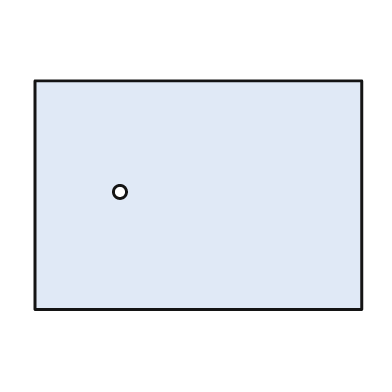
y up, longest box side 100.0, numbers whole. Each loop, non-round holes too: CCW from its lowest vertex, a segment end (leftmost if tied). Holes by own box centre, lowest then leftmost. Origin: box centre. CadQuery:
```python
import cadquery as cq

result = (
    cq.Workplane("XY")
    .moveTo(-50.0, -35.0)
    .lineTo(50.0, -35.0)
    .lineTo(50.0, 35.0)
    .lineTo(-50.0, 35.0)
    .close()
    .moveTo(-24.0, 1.0)
    .circle(2.0)
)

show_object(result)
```